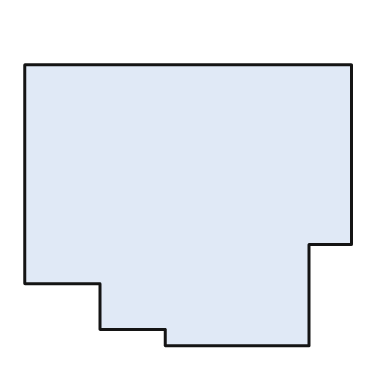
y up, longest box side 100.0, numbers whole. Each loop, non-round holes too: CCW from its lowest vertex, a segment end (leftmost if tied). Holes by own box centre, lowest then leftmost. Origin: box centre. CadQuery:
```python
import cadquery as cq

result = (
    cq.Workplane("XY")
    .moveTo(-7.0, -43.0)
    .lineTo(37.0, -43.0)
    .lineTo(37.0, -12.0)
    .lineTo(50.0, -12.0)
    .lineTo(50.0, 43.0)
    .lineTo(-50.0, 43.0)
    .lineTo(-50.0, -24.0)
    .lineTo(-27.0, -24.0)
    .lineTo(-27.0, -38.0)
    .lineTo(-7.0, -38.0)
    .close()
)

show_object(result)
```